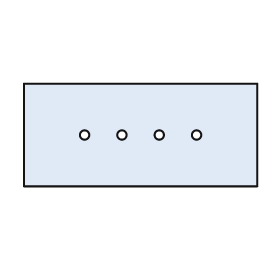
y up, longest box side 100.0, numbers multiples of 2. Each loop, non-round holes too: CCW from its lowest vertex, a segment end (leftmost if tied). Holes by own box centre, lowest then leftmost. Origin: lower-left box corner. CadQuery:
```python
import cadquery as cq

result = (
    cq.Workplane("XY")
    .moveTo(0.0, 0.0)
    .lineTo(100.0, 0.0)
    .lineTo(100.0, 44.0)
    .lineTo(0.0, 44.0)
    .close()
    .moveTo(26.0, 22.0)
    .circle(2.0)
    .moveTo(42.0, 22.0)
    .circle(2.0)
    .moveTo(58.0, 22.0)
    .circle(2.0)
    .moveTo(74.0, 22.0)
    .circle(2.0)
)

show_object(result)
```